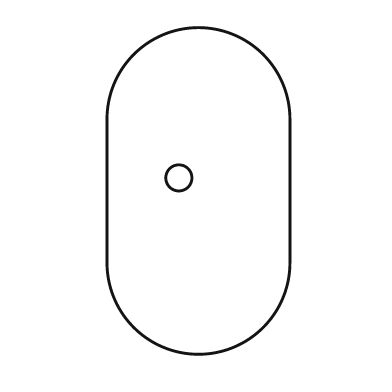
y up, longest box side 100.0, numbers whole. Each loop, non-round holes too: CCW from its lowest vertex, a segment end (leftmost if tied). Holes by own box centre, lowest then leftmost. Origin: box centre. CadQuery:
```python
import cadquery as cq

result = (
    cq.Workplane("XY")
    .moveTo(-28.0, -22.0)
    .threePointArc((0.0, -50.0), (28.0, -22.0))
    .lineTo(28.0, 22.0)
    .threePointArc((0.0, 50.0), (-28.0, 22.0))
    .close()
    .moveTo(-6.0, 4.0)
    .circle(4.0)
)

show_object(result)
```